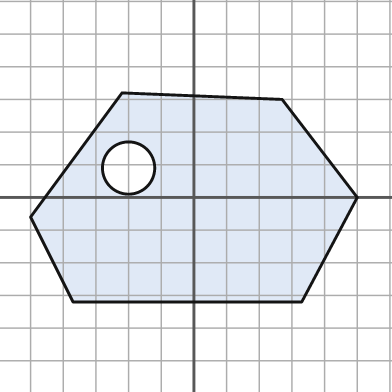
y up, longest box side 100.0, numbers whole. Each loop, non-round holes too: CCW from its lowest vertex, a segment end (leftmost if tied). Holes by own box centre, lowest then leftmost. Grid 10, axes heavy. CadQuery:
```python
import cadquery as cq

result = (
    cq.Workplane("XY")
    .moveTo(-37.0, -32.0)
    .lineTo(33.0, -32.0)
    .lineTo(50.0, 0.0)
    .lineTo(27.0, 30.0)
    .lineTo(-22.0, 32.0)
    .lineTo(-50.0, -6.0)
    .close()
    .moveTo(-20.0, 9.0)
    .circle(8.0)
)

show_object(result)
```